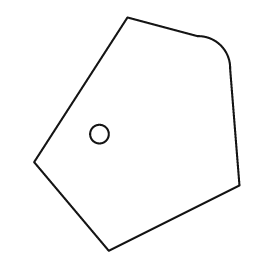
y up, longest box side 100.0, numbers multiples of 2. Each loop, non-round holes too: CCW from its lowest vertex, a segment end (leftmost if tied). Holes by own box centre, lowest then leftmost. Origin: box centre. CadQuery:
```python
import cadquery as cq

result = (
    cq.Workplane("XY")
    .moveTo(-12.0, -50.0)
    .lineTo(44.0, -22.0)
    .lineTo(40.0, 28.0)
    .threePointArc((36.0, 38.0), (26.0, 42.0))
    .lineTo(-4.0, 50.0)
    .lineTo(-44.0, -12.0)
    .close()
    .moveTo(-16.0, 0.0)
    .circle(4.0)
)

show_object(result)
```